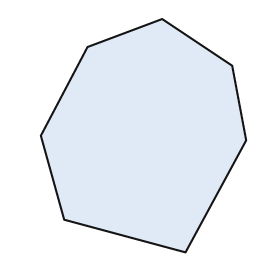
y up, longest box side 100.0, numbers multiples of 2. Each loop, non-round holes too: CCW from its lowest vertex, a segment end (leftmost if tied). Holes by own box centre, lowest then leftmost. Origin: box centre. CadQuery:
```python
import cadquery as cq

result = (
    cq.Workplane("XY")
    .moveTo(18.0, -50.0)
    .lineTo(44.0, -2.0)
    .lineTo(38.0, 30.0)
    .lineTo(8.0, 50.0)
    .lineTo(-24.0, 38.0)
    .lineTo(-44.0, 0.0)
    .lineTo(-34.0, -36.0)
    .close()
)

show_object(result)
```